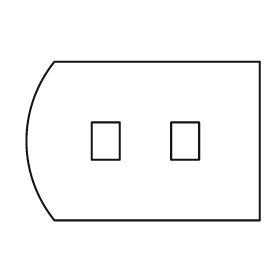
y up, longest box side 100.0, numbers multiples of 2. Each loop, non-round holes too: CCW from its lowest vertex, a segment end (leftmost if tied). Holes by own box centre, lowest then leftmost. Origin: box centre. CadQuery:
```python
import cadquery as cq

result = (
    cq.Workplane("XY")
    .moveTo(-38.0, -34.0)
    .lineTo(50.0, -34.0)
    .lineTo(50.0, 34.0)
    .lineTo(-38.0, 34.0)
    .threePointArc((-50.0, 0.0), (-38.0, -34.0))
    .close()
    .moveTo(-22.0, -8.0)
    .lineTo(-10.0, -8.0)
    .lineTo(-10.0, 8.0)
    .lineTo(-22.0, 8.0)
    .close()
    .moveTo(12.0, -8.0)
    .lineTo(24.0, -8.0)
    .lineTo(24.0, 8.0)
    .lineTo(12.0, 8.0)
    .close()
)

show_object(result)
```